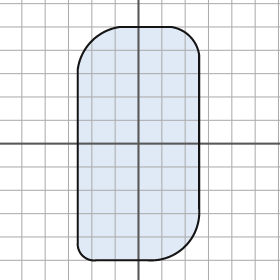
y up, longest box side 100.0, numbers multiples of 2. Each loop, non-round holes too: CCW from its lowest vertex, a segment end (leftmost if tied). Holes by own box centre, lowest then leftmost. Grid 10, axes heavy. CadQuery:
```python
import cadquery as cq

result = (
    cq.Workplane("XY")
    .moveTo(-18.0, -50.0)
    .lineTo(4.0, -50.0)
    .threePointArc((20.0, -44.0), (26.0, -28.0))
    .lineTo(26.0, 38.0)
    .threePointArc((22.0, 46.0), (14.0, 50.0))
    .lineTo(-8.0, 50.0)
    .threePointArc((-20.0, 44.0), (-26.0, 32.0))
    .lineTo(-26.0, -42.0)
    .threePointArc((-24.0, -48.0), (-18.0, -50.0))
    .close()
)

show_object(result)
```